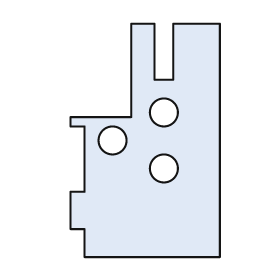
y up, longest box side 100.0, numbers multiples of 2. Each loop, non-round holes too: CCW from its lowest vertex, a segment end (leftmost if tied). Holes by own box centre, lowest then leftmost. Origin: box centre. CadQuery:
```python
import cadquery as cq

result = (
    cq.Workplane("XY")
    .moveTo(-26.0, -50.0)
    .lineTo(32.0, -50.0)
    .lineTo(32.0, 50.0)
    .lineTo(12.0, 50.0)
    .lineTo(12.0, 26.0)
    .lineTo(4.0, 26.0)
    .lineTo(4.0, 50.0)
    .lineTo(-6.0, 50.0)
    .lineTo(-6.0, 10.0)
    .lineTo(-32.0, 10.0)
    .lineTo(-32.0, 6.0)
    .lineTo(-26.0, 6.0)
    .lineTo(-26.0, -22.0)
    .lineTo(-32.0, -22.0)
    .lineTo(-32.0, -38.0)
    .lineTo(-26.0, -38.0)
    .close()
    .moveTo(8.0, -12.0)
    .circle(6.0)
    .moveTo(-14.0, 0.0)
    .circle(6.0)
    .moveTo(8.0, 12.0)
    .circle(6.0)
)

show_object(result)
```